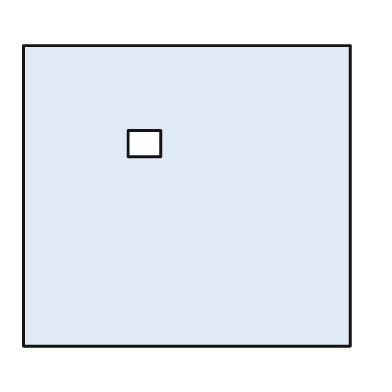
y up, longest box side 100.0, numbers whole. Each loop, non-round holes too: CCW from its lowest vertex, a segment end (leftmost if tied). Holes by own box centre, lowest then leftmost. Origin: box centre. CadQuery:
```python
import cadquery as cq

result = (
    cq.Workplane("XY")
    .moveTo(-50.0, -46.0)
    .lineTo(50.0, -46.0)
    .lineTo(50.0, 46.0)
    .lineTo(-50.0, 46.0)
    .close()
    .moveTo(-18.0, 12.0)
    .lineTo(-8.0, 12.0)
    .lineTo(-8.0, 20.0)
    .lineTo(-18.0, 20.0)
    .close()
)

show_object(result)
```